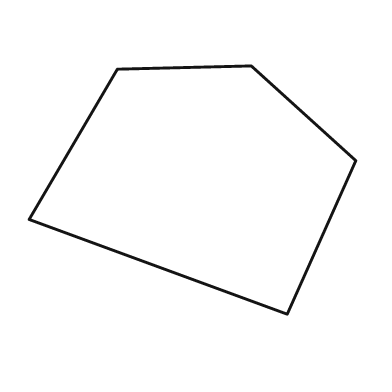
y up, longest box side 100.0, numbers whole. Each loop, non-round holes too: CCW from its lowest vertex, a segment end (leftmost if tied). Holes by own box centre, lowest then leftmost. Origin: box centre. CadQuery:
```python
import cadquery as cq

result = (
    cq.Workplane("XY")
    .moveTo(29.0, -38.0)
    .lineTo(50.0, 9.0)
    .lineTo(18.0, 38.0)
    .lineTo(-23.0, 37.0)
    .lineTo(-50.0, -9.0)
    .close()
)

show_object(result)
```